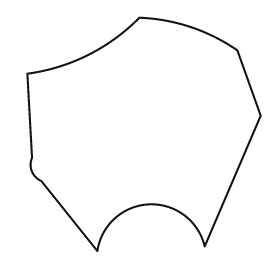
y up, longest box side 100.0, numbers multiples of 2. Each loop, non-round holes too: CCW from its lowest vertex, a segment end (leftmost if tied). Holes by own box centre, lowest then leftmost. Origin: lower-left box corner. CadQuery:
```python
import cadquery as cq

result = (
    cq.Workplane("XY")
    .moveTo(30.0, 0.0)
    .threePointArc((52.0, 20.0), (76.0, 2.0))
    .lineTo(100.0, 58.0)
    .lineTo(90.0, 86.0)
    .threePointArc((70.0, 96.0), (48.0, 100.0))
    .threePointArc((26.0, 84.0), (0.0, 76.0))
    .lineTo(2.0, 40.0)
    .threePointArc((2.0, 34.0), (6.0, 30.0))
    .close()
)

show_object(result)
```